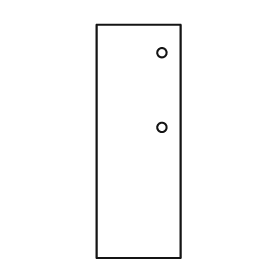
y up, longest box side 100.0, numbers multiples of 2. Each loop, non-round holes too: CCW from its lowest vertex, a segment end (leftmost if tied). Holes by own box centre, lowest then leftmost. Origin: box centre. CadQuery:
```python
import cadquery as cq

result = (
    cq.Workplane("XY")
    .moveTo(-18.0, -50.0)
    .lineTo(18.0, -50.0)
    .lineTo(18.0, 50.0)
    .lineTo(-18.0, 50.0)
    .close()
    .moveTo(10.0, 6.0)
    .circle(2.0)
    .moveTo(10.0, 38.0)
    .circle(2.0)
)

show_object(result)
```